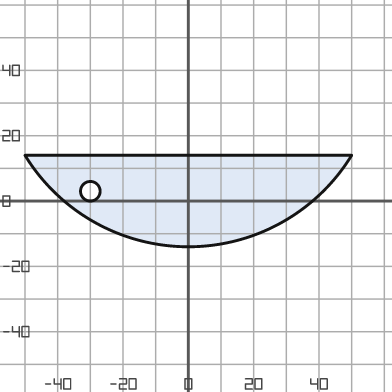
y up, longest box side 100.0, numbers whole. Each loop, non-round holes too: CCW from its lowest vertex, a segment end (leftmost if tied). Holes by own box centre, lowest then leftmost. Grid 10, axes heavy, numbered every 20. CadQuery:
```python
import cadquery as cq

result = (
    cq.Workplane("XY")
    .moveTo(-50.0, 14.0)
    .threePointArc((0.0, -14.0), (50.0, 14.0))
    .close()
    .moveTo(-30.0, 3.0)
    .circle(3.0)
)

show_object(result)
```